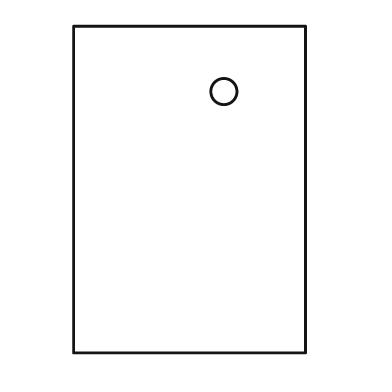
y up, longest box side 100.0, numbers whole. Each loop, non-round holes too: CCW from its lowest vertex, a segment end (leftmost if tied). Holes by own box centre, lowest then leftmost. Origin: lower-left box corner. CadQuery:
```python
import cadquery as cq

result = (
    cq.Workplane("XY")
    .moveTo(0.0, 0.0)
    .lineTo(71.0, 0.0)
    .lineTo(71.0, 100.0)
    .lineTo(0.0, 100.0)
    .close()
    .moveTo(46.0, 80.0)
    .circle(4.0)
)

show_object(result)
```